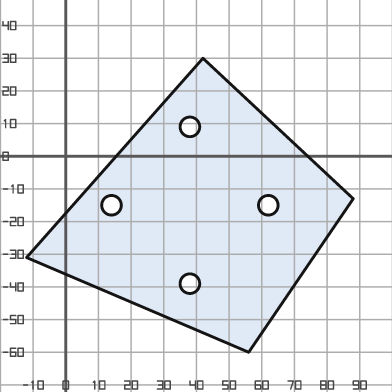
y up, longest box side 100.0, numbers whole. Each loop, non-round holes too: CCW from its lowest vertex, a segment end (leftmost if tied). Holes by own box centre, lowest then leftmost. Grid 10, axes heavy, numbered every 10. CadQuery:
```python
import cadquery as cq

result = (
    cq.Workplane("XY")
    .moveTo(56.0, -60.0)
    .lineTo(88.0, -13.0)
    .lineTo(42.0, 30.0)
    .lineTo(-12.0, -31.0)
    .close()
    .moveTo(38.0, -39.0)
    .circle(3.0)
    .moveTo(14.0, -15.0)
    .circle(3.0)
    .moveTo(62.0, -15.0)
    .circle(3.0)
    .moveTo(38.0, 9.0)
    .circle(3.0)
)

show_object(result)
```